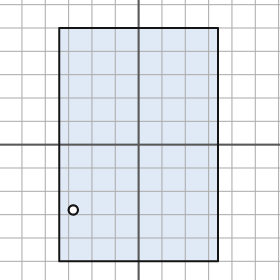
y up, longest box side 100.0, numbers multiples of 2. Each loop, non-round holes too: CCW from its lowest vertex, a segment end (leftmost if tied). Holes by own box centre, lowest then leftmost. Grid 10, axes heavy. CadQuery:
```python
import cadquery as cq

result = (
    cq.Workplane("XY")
    .moveTo(-34.0, -50.0)
    .lineTo(34.0, -50.0)
    .lineTo(34.0, 50.0)
    .lineTo(-34.0, 50.0)
    .close()
    .moveTo(-28.0, -28.0)
    .circle(2.0)
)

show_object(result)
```